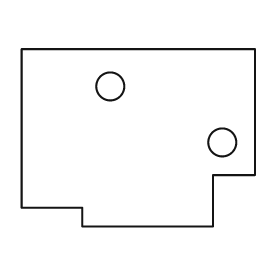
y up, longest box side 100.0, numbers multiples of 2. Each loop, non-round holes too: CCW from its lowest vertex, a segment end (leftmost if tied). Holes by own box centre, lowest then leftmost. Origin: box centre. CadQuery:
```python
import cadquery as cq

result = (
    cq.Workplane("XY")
    .moveTo(-24.0, -38.0)
    .lineTo(32.0, -38.0)
    .lineTo(32.0, -16.0)
    .lineTo(50.0, -16.0)
    .lineTo(50.0, 38.0)
    .lineTo(-50.0, 38.0)
    .lineTo(-50.0, -30.0)
    .lineTo(-24.0, -30.0)
    .close()
    .moveTo(36.0, -2.0)
    .circle(6.0)
    .moveTo(-12.0, 22.0)
    .circle(6.0)
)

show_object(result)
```